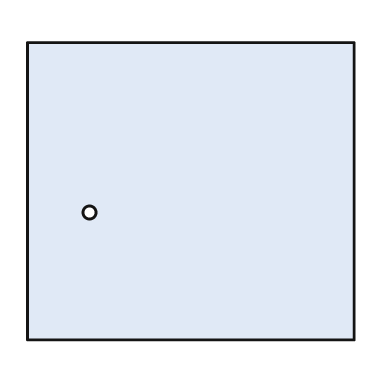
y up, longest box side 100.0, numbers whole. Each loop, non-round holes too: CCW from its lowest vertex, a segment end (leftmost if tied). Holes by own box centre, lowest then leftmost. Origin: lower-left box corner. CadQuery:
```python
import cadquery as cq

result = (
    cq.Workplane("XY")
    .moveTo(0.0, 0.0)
    .lineTo(100.0, 0.0)
    .lineTo(100.0, 91.0)
    .lineTo(0.0, 91.0)
    .close()
    .moveTo(19.0, 39.0)
    .circle(2.0)
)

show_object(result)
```